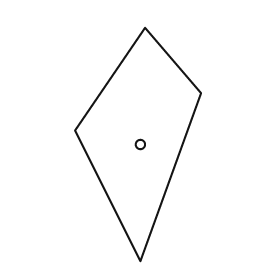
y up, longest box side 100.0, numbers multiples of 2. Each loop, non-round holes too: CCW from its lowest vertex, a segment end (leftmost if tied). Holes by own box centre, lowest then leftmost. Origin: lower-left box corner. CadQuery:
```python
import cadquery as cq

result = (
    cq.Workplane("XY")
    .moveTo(28.0, 0.0)
    .lineTo(54.0, 72.0)
    .lineTo(30.0, 100.0)
    .lineTo(0.0, 56.0)
    .close()
    .moveTo(28.0, 50.0)
    .circle(2.0)
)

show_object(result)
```